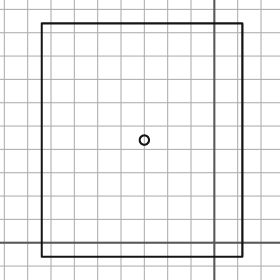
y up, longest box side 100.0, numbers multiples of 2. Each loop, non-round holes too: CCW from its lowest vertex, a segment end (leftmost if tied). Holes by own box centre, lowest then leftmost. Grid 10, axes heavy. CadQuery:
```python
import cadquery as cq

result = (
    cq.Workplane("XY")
    .moveTo(-74.0, -6.0)
    .lineTo(12.0, -6.0)
    .lineTo(12.0, 94.0)
    .lineTo(-74.0, 94.0)
    .close()
    .moveTo(-30.0, 44.0)
    .circle(2.0)
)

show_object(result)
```